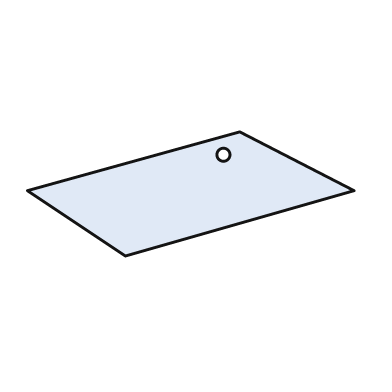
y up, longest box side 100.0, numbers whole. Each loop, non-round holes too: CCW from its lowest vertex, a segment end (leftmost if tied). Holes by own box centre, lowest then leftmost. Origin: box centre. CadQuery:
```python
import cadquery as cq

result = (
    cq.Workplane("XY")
    .moveTo(-20.0, -19.0)
    .lineTo(50.0, 1.0)
    .lineTo(15.0, 19.0)
    .lineTo(-50.0, 1.0)
    .close()
    .moveTo(10.0, 12.0)
    .circle(2.0)
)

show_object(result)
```